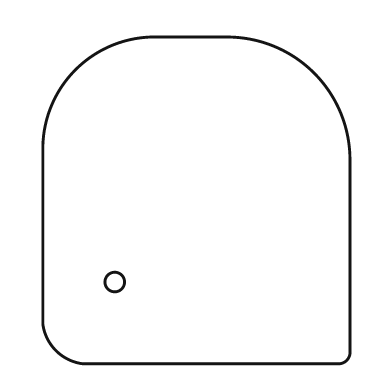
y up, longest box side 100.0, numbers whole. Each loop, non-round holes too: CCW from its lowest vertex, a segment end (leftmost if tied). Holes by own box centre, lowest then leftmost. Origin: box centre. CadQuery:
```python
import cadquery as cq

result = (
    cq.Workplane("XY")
    .moveTo(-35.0, -50.0)
    .lineTo(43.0, -50.0)
    .threePointArc((46.0, -49.0), (47.0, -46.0))
    .lineTo(47.0, 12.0)
    .threePointArc((36.0, 39.0), (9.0, 50.0))
    .lineTo(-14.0, 50.0)
    .threePointArc((-37.0, 40.0), (-47.0, 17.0))
    .lineTo(-47.0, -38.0)
    .threePointArc((-43.0, -46.0), (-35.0, -50.0))
    .close()
    .moveTo(-25.0, -25.0)
    .circle(3.0)
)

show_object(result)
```